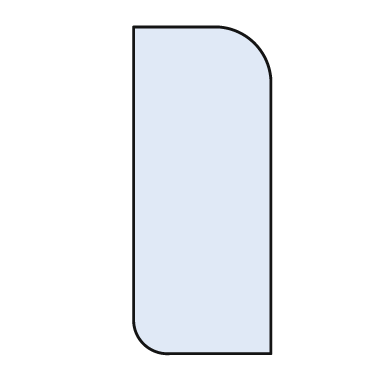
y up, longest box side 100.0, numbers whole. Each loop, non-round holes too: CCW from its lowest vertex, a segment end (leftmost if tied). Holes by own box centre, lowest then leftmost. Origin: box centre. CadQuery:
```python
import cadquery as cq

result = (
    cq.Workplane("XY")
    .moveTo(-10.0, -50.0)
    .lineTo(21.0, -50.0)
    .lineTo(21.0, 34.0)
    .threePointArc((16.0, 45.0), (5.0, 50.0))
    .lineTo(-21.0, 50.0)
    .lineTo(-21.0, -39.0)
    .threePointArc((-18.0, -47.0), (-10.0, -50.0))
    .close()
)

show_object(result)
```